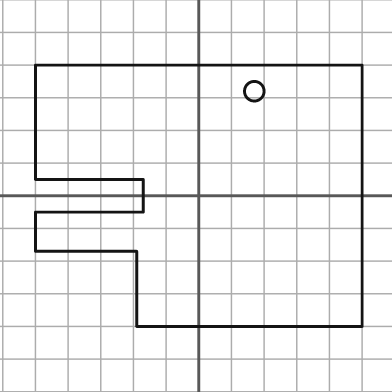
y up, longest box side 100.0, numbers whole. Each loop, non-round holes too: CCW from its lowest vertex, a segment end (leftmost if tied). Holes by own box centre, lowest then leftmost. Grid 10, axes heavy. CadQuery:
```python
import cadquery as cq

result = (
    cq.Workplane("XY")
    .moveTo(-19.0, -40.0)
    .lineTo(50.0, -40.0)
    .lineTo(50.0, 40.0)
    .lineTo(-50.0, 40.0)
    .lineTo(-50.0, 5.0)
    .lineTo(-17.0, 5.0)
    .lineTo(-17.0, -5.0)
    .lineTo(-50.0, -5.0)
    .lineTo(-50.0, -17.0)
    .lineTo(-19.0, -17.0)
    .close()
    .moveTo(17.0, 32.0)
    .circle(3.0)
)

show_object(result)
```